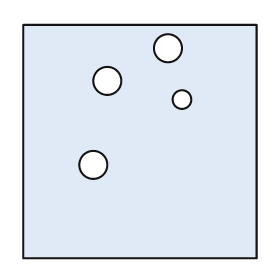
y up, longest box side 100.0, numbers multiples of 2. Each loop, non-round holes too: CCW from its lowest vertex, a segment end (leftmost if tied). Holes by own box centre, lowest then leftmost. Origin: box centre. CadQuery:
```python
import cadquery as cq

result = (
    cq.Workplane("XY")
    .moveTo(-50.0, -50.0)
    .lineTo(50.0, -50.0)
    .lineTo(50.0, 50.0)
    .lineTo(-50.0, 50.0)
    .close()
    .moveTo(-20.0, -10.0)
    .circle(6.0)
    .moveTo(18.0, 18.0)
    .circle(4.0)
    .moveTo(-14.0, 26.0)
    .circle(6.0)
    .moveTo(12.0, 40.0)
    .circle(6.0)
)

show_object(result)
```